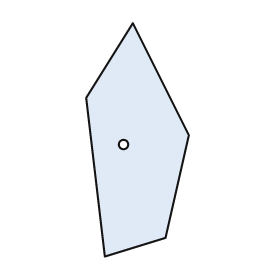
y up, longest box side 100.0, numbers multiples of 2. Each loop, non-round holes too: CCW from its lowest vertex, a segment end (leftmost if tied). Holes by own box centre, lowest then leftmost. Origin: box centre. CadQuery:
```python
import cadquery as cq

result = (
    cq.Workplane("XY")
    .moveTo(-14.0, -50.0)
    .lineTo(12.0, -42.0)
    .lineTo(22.0, 2.0)
    .lineTo(-2.0, 50.0)
    .lineTo(-22.0, 18.0)
    .close()
    .moveTo(-6.0, -2.0)
    .circle(2.0)
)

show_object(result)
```